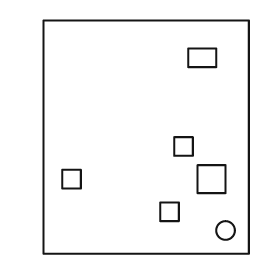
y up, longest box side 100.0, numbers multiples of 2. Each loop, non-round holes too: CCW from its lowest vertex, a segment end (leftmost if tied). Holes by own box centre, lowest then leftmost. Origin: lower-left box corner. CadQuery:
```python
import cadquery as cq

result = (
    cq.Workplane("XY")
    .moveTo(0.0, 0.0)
    .lineTo(88.0, 0.0)
    .lineTo(88.0, 100.0)
    .lineTo(0.0, 100.0)
    .close()
    .moveTo(78.0, 10.0)
    .circle(4.0)
    .moveTo(50.0, 14.0)
    .lineTo(58.0, 14.0)
    .lineTo(58.0, 22.0)
    .lineTo(50.0, 22.0)
    .close()
    .moveTo(8.0, 28.0)
    .lineTo(16.0, 28.0)
    .lineTo(16.0, 36.0)
    .lineTo(8.0, 36.0)
    .close()
    .moveTo(66.0, 26.0)
    .lineTo(78.0, 26.0)
    .lineTo(78.0, 38.0)
    .lineTo(66.0, 38.0)
    .close()
    .moveTo(56.0, 42.0)
    .lineTo(64.0, 42.0)
    .lineTo(64.0, 50.0)
    .lineTo(56.0, 50.0)
    .close()
    .moveTo(62.0, 80.0)
    .lineTo(74.0, 80.0)
    .lineTo(74.0, 88.0)
    .lineTo(62.0, 88.0)
    .close()
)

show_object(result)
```